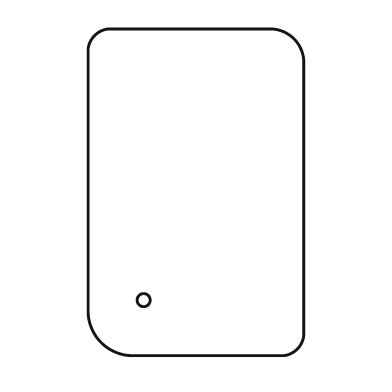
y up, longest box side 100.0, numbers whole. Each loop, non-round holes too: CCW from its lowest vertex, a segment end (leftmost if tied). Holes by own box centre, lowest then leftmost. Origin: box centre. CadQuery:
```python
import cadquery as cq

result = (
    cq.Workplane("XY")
    .moveTo(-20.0, -50.0)
    .lineTo(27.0, -50.0)
    .threePointArc((31.0, -48.0), (33.0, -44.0))
    .lineTo(33.0, 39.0)
    .threePointArc((30.0, 47.0), (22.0, 50.0))
    .lineTo(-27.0, 50.0)
    .threePointArc((-31.0, 48.0), (-33.0, 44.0))
    .lineTo(-33.0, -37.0)
    .threePointArc((-29.0, -46.0), (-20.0, -50.0))
    .close()
    .moveTo(-16.0, -33.0)
    .circle(2.0)
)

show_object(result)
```